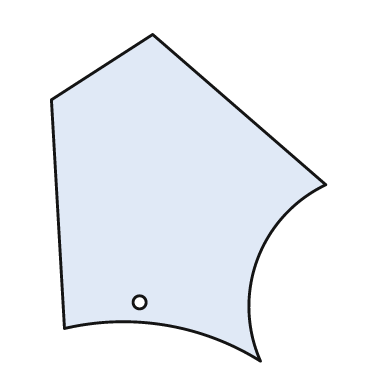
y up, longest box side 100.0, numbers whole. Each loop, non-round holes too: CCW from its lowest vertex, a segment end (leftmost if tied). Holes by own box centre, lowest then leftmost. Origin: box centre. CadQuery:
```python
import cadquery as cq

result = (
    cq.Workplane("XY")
    .moveTo(22.0, -50.0)
    .threePointArc((21.0, -19.0), (42.0, 4.0))
    .lineTo(-11.0, 50.0)
    .lineTo(-42.0, 30.0)
    .lineTo(-38.0, -40.0)
    .threePointArc((-7.0, -39.0), (22.0, -50.0))
    .close()
    .moveTo(-15.0, -32.0)
    .circle(2.0)
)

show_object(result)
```